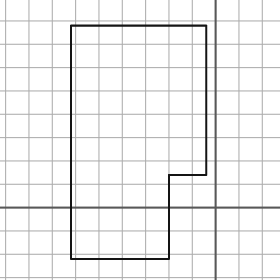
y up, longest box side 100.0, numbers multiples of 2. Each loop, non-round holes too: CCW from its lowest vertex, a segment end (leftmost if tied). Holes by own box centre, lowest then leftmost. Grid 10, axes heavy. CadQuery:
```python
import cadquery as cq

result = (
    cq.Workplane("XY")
    .moveTo(-62.0, -22.0)
    .lineTo(-20.0, -22.0)
    .lineTo(-20.0, 14.0)
    .lineTo(-4.0, 14.0)
    .lineTo(-4.0, 78.0)
    .lineTo(-62.0, 78.0)
    .close()
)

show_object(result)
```